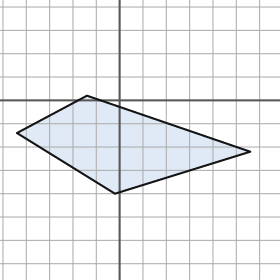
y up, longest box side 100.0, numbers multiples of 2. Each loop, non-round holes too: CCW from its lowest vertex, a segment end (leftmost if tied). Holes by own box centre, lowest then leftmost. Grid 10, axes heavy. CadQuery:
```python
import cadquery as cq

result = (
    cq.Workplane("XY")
    .moveTo(-2.0, -40.0)
    .lineTo(56.0, -22.0)
    .lineTo(-14.0, 2.0)
    .lineTo(-44.0, -14.0)
    .close()
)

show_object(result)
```